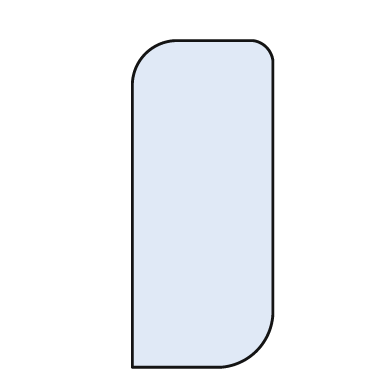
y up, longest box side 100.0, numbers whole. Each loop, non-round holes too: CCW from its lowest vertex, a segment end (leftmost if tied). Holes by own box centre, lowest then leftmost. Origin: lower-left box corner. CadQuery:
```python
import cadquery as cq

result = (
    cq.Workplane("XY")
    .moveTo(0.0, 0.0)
    .lineTo(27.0, 0.0)
    .threePointArc((38.0, 5.0), (43.0, 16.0))
    .lineTo(43.0, 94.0)
    .threePointArc((41.0, 98.0), (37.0, 100.0))
    .lineTo(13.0, 100.0)
    .threePointArc((4.0, 96.0), (0.0, 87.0))
    .close()
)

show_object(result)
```